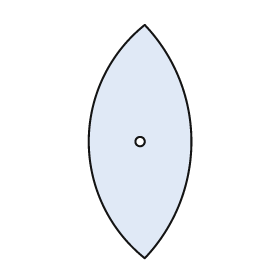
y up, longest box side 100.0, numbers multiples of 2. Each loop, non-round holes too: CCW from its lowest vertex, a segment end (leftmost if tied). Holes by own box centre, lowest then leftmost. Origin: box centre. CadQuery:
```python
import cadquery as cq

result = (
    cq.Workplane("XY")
    .moveTo(2.0, -50.0)
    .threePointArc((22.0, 0.0), (2.0, 50.0))
    .threePointArc((-22.0, 0.0), (2.0, -50.0))
    .close()
    .moveTo(0.0, 0.0)
    .circle(2.0)
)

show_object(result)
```